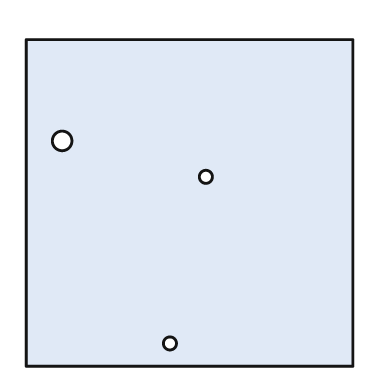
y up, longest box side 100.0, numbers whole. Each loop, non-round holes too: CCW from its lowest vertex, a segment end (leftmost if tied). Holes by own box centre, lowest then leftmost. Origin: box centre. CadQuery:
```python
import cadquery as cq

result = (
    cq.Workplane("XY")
    .moveTo(-50.0, -50.0)
    .lineTo(50.0, -50.0)
    .lineTo(50.0, 50.0)
    .lineTo(-50.0, 50.0)
    .close()
    .moveTo(-6.0, -43.0)
    .circle(2.0)
    .moveTo(5.0, 8.0)
    .circle(2.0)
    .moveTo(-39.0, 19.0)
    .circle(3.0)
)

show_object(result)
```